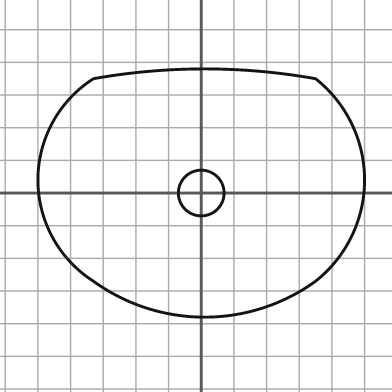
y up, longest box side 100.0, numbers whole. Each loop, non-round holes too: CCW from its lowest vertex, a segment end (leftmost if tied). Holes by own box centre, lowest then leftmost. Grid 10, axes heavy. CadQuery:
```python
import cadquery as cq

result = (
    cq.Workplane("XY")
    .moveTo(-33.0, -27.0)
    .threePointArc((1.0, -38.0), (35.0, -27.0))
    .threePointArc((50.0, 4.0), (35.0, 35.0))
    .threePointArc((1.0, 38.0), (-33.0, 35.0))
    .threePointArc((-50.0, 4.0), (-33.0, -27.0))
    .close()
    .moveTo(0.0, 0.0)
    .circle(7.0)
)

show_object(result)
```